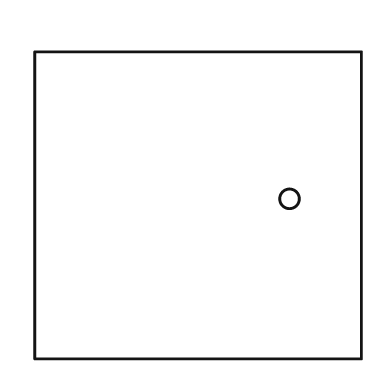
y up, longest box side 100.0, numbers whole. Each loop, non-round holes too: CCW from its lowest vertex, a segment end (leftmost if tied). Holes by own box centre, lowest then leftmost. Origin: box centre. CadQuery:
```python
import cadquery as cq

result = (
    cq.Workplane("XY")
    .moveTo(-50.0, -47.0)
    .lineTo(50.0, -47.0)
    .lineTo(50.0, 47.0)
    .lineTo(-50.0, 47.0)
    .close()
    .moveTo(28.0, 2.0)
    .circle(3.0)
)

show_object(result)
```